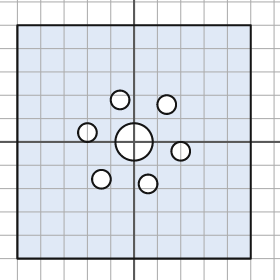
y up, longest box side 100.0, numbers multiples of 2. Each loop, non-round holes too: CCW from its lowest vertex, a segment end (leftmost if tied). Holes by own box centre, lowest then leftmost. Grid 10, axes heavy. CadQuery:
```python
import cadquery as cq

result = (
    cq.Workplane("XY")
    .moveTo(-50.0, -50.0)
    .lineTo(50.0, -50.0)
    .lineTo(50.0, 50.0)
    .lineTo(-50.0, 50.0)
    .close()
    .moveTo(6.0, -18.0)
    .circle(4.0)
    .moveTo(-14.0, -16.0)
    .circle(4.0)
    .moveTo(20.0, -4.0)
    .circle(4.0)
    .moveTo(0.0, 0.0)
    .circle(8.0)
    .moveTo(-20.0, 4.0)
    .circle(4.0)
    .moveTo(14.0, 16.0)
    .circle(4.0)
    .moveTo(-6.0, 18.0)
    .circle(4.0)
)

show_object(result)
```